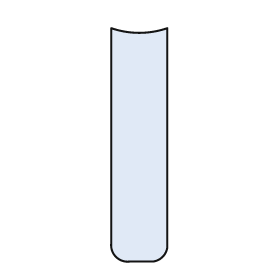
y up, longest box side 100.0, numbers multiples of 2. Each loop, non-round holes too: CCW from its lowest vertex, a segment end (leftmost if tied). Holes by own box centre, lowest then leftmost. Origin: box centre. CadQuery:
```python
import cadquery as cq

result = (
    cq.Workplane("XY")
    .moveTo(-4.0, -50.0)
    .lineTo(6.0, -50.0)
    .threePointArc((10.0, -48.0), (12.0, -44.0))
    .lineTo(12.0, 50.0)
    .threePointArc((0.0, 48.0), (-12.0, 50.0))
    .lineTo(-12.0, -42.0)
    .threePointArc((-10.0, -48.0), (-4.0, -50.0))
    .close()
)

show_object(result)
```